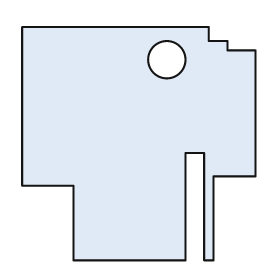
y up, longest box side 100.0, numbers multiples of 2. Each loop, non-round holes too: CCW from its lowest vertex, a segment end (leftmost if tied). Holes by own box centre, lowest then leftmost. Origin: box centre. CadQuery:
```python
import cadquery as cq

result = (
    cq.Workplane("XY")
    .moveTo(-28.0, -50.0)
    .lineTo(20.0, -50.0)
    .lineTo(20.0, -4.0)
    .lineTo(28.0, -4.0)
    .lineTo(28.0, -50.0)
    .lineTo(32.0, -50.0)
    .lineTo(32.0, -14.0)
    .lineTo(50.0, -14.0)
    .lineTo(50.0, 40.0)
    .lineTo(38.0, 40.0)
    .lineTo(38.0, 44.0)
    .lineTo(30.0, 44.0)
    .lineTo(30.0, 50.0)
    .lineTo(-50.0, 50.0)
    .lineTo(-50.0, -18.0)
    .lineTo(-28.0, -18.0)
    .close()
    .moveTo(12.0, 36.0)
    .circle(8.0)
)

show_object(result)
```